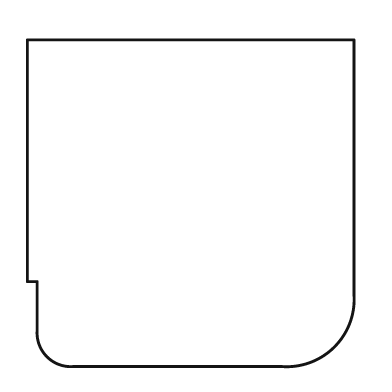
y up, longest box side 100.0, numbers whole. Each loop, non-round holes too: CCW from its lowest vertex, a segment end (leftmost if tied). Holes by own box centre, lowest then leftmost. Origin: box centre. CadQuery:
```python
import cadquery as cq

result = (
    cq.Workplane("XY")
    .moveTo(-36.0, -50.0)
    .lineTo(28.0, -50.0)
    .threePointArc((44.0, -44.0), (50.0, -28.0))
    .lineTo(50.0, 50.0)
    .lineTo(-50.0, 50.0)
    .lineTo(-50.0, -24.0)
    .lineTo(-47.0, -24.0)
    .lineTo(-47.0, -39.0)
    .threePointArc((-44.0, -47.0), (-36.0, -50.0))
    .close()
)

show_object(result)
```